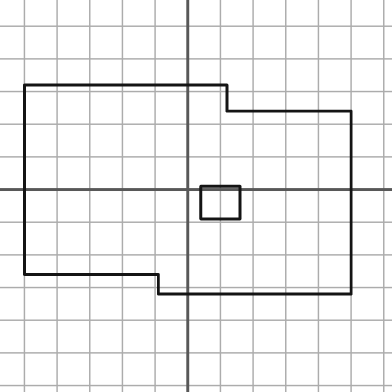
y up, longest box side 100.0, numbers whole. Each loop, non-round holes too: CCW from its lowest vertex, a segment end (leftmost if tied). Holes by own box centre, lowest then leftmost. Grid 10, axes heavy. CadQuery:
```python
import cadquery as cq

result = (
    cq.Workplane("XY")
    .moveTo(-9.0, -32.0)
    .lineTo(50.0, -32.0)
    .lineTo(50.0, 24.0)
    .lineTo(12.0, 24.0)
    .lineTo(12.0, 32.0)
    .lineTo(-50.0, 32.0)
    .lineTo(-50.0, -26.0)
    .lineTo(-9.0, -26.0)
    .close()
    .moveTo(4.0, -9.0)
    .lineTo(16.0, -9.0)
    .lineTo(16.0, 1.0)
    .lineTo(4.0, 1.0)
    .close()
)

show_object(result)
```